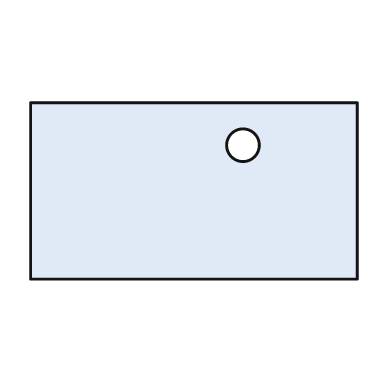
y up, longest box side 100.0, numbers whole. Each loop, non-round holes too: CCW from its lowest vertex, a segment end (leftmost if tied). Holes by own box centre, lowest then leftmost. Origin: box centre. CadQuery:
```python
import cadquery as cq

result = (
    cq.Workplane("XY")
    .moveTo(-50.0, -27.0)
    .lineTo(50.0, -27.0)
    .lineTo(50.0, 27.0)
    .lineTo(-50.0, 27.0)
    .close()
    .moveTo(15.0, 14.0)
    .circle(5.0)
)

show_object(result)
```